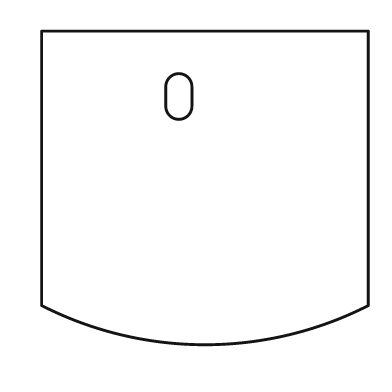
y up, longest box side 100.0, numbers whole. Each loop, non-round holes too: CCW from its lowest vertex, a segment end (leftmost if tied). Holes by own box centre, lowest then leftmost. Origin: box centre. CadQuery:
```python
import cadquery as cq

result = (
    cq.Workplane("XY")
    .moveTo(-50.0, -36.0)
    .threePointArc((0.0, -48.0), (50.0, -36.0))
    .lineTo(50.0, 48.0)
    .lineTo(-50.0, 48.0)
    .close()
    .moveTo(-12.0, 25.0)
    .threePointArc((-8.0, 21.0), (-4.0, 25.0))
    .lineTo(-4.0, 31.0)
    .threePointArc((-8.0, 35.0), (-12.0, 31.0))
    .close()
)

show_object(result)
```